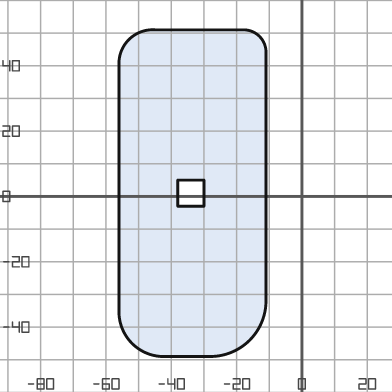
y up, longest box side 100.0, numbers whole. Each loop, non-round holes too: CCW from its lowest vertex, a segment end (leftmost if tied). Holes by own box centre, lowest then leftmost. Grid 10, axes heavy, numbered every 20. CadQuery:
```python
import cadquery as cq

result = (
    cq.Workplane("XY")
    .moveTo(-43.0, -49.0)
    .lineTo(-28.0, -49.0)
    .threePointArc((-16.0, -44.0), (-11.0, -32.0))
    .lineTo(-11.0, 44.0)
    .threePointArc((-13.0, 49.0), (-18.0, 51.0))
    .lineTo(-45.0, 51.0)
    .threePointArc((-53.0, 48.0), (-56.0, 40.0))
    .lineTo(-56.0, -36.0)
    .threePointArc((-52.0, -45.0), (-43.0, -49.0))
    .close()
    .moveTo(-38.0, -3.0)
    .lineTo(-30.0, -3.0)
    .lineTo(-30.0, 5.0)
    .lineTo(-38.0, 5.0)
    .close()
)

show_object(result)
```